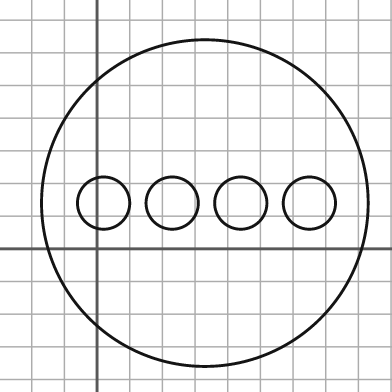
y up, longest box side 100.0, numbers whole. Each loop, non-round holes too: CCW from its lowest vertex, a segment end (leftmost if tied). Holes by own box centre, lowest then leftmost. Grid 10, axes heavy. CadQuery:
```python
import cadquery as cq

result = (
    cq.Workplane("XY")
    .moveTo(33.0, 14.0)
    .circle(50.0)
    .moveTo(2.0, 14.0)
    .circle(8.0)
    .moveTo(23.0, 14.0)
    .circle(8.0)
    .moveTo(44.0, 14.0)
    .circle(8.0)
    .moveTo(65.0, 14.0)
    .circle(8.0)
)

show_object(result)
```